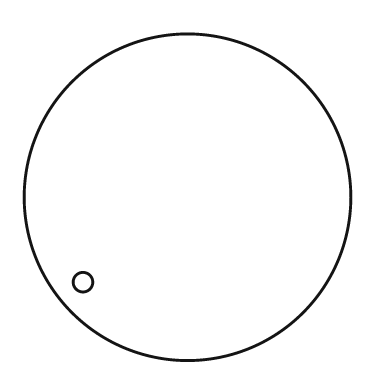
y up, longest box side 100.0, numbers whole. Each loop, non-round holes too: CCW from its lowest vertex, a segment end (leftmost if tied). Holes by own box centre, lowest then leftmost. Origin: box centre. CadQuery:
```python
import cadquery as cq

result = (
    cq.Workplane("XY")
    .moveTo(0.0, 0.0)
    .circle(50.0)
    .moveTo(-32.0, -26.0)
    .circle(3.0)
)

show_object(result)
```